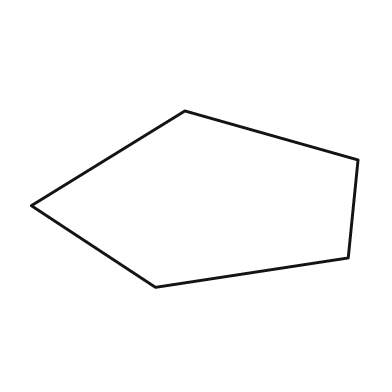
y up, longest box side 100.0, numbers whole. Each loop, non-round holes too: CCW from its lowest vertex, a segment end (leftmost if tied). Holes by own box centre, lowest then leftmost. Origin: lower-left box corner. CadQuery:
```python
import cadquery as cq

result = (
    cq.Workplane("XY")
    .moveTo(38.0, 0.0)
    .lineTo(97.0, 9.0)
    .lineTo(100.0, 39.0)
    .lineTo(47.0, 54.0)
    .lineTo(0.0, 25.0)
    .close()
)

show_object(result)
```